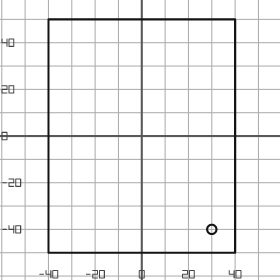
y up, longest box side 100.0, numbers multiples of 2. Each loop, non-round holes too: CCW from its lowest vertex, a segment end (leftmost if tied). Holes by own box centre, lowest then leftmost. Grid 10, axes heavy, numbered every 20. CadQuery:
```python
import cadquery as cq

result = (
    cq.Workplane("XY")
    .moveTo(-40.0, -50.0)
    .lineTo(40.0, -50.0)
    .lineTo(40.0, 50.0)
    .lineTo(-40.0, 50.0)
    .close()
    .moveTo(30.0, -40.0)
    .circle(2.0)
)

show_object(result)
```